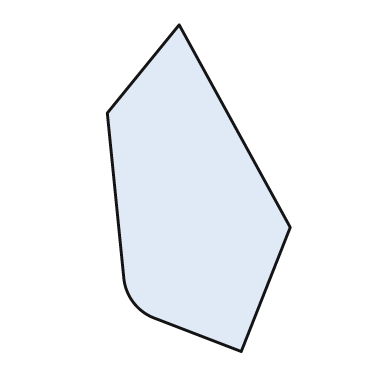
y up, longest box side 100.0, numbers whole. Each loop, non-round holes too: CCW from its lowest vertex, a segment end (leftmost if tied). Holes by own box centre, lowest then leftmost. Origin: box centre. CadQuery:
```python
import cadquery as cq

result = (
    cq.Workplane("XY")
    .moveTo(13.0, -50.0)
    .lineTo(28.0, -12.0)
    .lineTo(-6.0, 50.0)
    .lineTo(-28.0, 23.0)
    .lineTo(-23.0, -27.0)
    .threePointArc((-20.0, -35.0), (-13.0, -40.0))
    .close()
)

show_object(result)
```